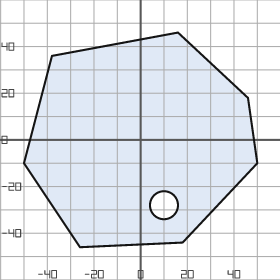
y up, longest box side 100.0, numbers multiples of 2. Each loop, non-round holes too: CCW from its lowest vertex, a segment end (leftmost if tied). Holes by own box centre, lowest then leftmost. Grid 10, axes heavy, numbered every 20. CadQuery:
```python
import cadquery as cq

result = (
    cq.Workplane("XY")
    .moveTo(-26.0, -46.0)
    .lineTo(18.0, -44.0)
    .lineTo(50.0, -10.0)
    .lineTo(46.0, 18.0)
    .lineTo(16.0, 46.0)
    .lineTo(-38.0, 36.0)
    .lineTo(-50.0, -10.0)
    .close()
    .moveTo(10.0, -28.0)
    .circle(6.0)
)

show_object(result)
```